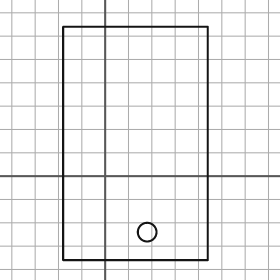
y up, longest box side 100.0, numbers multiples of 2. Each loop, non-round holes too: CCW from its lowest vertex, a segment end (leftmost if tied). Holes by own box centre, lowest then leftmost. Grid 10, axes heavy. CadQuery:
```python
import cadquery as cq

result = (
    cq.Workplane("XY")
    .moveTo(-18.0, -36.0)
    .lineTo(44.0, -36.0)
    .lineTo(44.0, 64.0)
    .lineTo(-18.0, 64.0)
    .close()
    .moveTo(18.0, -24.0)
    .circle(4.0)
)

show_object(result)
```